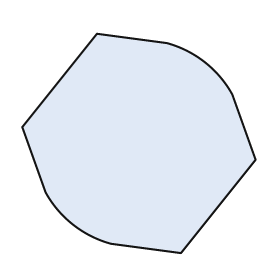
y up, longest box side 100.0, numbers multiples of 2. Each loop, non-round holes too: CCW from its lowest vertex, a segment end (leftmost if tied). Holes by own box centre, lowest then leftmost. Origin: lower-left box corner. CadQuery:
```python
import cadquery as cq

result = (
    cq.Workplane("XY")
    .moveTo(68.0, 0.0)
    .lineTo(100.0, 40.0)
    .lineTo(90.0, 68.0)
    .threePointArc((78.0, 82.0), (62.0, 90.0))
    .lineTo(32.0, 94.0)
    .lineTo(0.0, 54.0)
    .lineTo(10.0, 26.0)
    .threePointArc((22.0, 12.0), (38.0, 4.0))
    .close()
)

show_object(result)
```